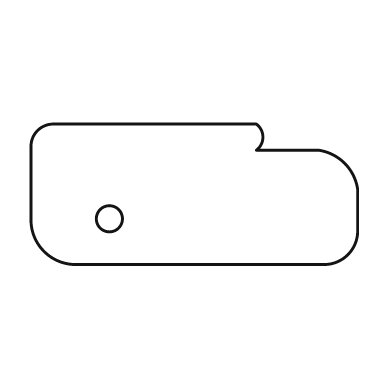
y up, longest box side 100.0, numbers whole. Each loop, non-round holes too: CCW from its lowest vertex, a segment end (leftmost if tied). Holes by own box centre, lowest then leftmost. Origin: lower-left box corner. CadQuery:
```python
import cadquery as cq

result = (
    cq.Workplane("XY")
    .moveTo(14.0, 0.0)
    .lineTo(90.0, 0.0)
    .threePointArc((97.0, 3.0), (100.0, 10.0))
    .lineTo(100.0, 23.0)
    .threePointArc((96.0, 31.0), (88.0, 35.0))
    .lineTo(69.0, 35.0)
    .threePointArc((71.0, 39.0), (69.0, 43.0))
    .lineTo(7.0, 43.0)
    .threePointArc((2.0, 41.0), (0.0, 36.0))
    .lineTo(0.0, 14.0)
    .threePointArc((4.0, 4.0), (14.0, 0.0))
    .close()
    .moveTo(24.0, 14.0)
    .circle(4.0)
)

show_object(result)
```